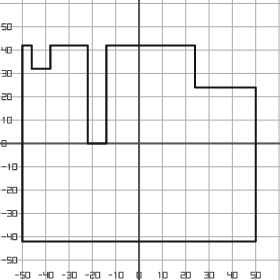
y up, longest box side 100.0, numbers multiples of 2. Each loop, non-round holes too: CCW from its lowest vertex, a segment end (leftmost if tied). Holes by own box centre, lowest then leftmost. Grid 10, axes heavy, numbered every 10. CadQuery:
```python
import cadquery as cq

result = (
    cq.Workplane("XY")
    .moveTo(-50.0, -42.0)
    .lineTo(50.0, -42.0)
    .lineTo(50.0, 24.0)
    .lineTo(24.0, 24.0)
    .lineTo(24.0, 42.0)
    .lineTo(-14.0, 42.0)
    .lineTo(-14.0, 0.0)
    .lineTo(-22.0, 0.0)
    .lineTo(-22.0, 42.0)
    .lineTo(-38.0, 42.0)
    .lineTo(-38.0, 32.0)
    .lineTo(-46.0, 32.0)
    .lineTo(-46.0, 42.0)
    .lineTo(-50.0, 42.0)
    .close()
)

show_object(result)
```